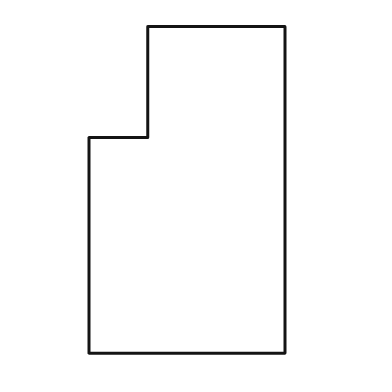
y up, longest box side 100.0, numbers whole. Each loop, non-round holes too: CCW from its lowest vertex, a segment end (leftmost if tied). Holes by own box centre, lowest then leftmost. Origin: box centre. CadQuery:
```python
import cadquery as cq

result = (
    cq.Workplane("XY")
    .moveTo(-30.0, -50.0)
    .lineTo(30.0, -50.0)
    .lineTo(30.0, 50.0)
    .lineTo(-12.0, 50.0)
    .lineTo(-12.0, 16.0)
    .lineTo(-30.0, 16.0)
    .close()
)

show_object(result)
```